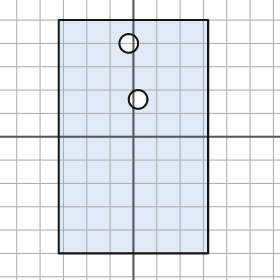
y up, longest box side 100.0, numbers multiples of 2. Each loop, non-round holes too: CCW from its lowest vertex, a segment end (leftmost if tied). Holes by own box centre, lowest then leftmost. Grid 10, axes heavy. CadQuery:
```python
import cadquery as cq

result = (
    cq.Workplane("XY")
    .moveTo(-32.0, -50.0)
    .lineTo(32.0, -50.0)
    .lineTo(32.0, 50.0)
    .lineTo(-32.0, 50.0)
    .close()
    .moveTo(2.0, 16.0)
    .circle(4.0)
    .moveTo(-2.0, 40.0)
    .circle(4.0)
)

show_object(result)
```